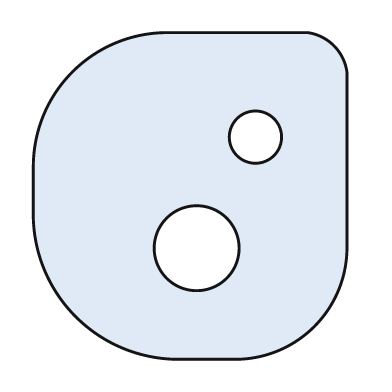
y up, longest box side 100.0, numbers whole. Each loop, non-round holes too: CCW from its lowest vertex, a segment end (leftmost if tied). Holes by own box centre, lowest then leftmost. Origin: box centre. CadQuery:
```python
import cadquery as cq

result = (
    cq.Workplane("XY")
    .moveTo(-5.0, -50.0)
    .lineTo(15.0, -50.0)
    .threePointArc((38.0, -40.0), (48.0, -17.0))
    .lineTo(48.0, 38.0)
    .threePointArc((44.0, 46.0), (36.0, 50.0))
    .lineTo(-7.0, 50.0)
    .threePointArc((-36.0, 38.0), (-48.0, 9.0))
    .lineTo(-48.0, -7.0)
    .threePointArc((-35.0, -37.0), (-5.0, -50.0))
    .close()
    .moveTo(2.0, -16.0)
    .circle(13.0)
    .moveTo(20.0, 18.0)
    .circle(8.0)
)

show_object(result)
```